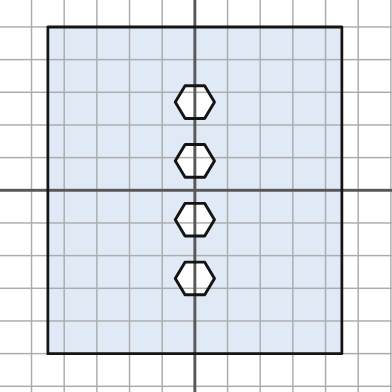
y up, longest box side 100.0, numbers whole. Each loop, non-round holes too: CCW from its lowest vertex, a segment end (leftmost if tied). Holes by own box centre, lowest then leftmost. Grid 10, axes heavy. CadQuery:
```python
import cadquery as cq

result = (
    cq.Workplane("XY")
    .moveTo(-45.0, -50.0)
    .lineTo(45.0, -50.0)
    .lineTo(45.0, 50.0)
    .lineTo(-45.0, 50.0)
    .close()
    .moveTo(-3.0, -32.0)
    .lineTo(3.0, -32.0)
    .lineTo(6.0, -27.0)
    .lineTo(3.0, -22.0)
    .lineTo(-3.0, -22.0)
    .lineTo(-6.0, -27.0)
    .close()
    .moveTo(-3.0, -14.0)
    .lineTo(3.0, -14.0)
    .lineTo(6.0, -9.0)
    .lineTo(3.0, -4.0)
    .lineTo(-3.0, -4.0)
    .lineTo(-6.0, -9.0)
    .close()
    .moveTo(-3.0, 4.0)
    .lineTo(3.0, 4.0)
    .lineTo(6.0, 9.0)
    .lineTo(3.0, 14.0)
    .lineTo(-3.0, 14.0)
    .lineTo(-6.0, 9.0)
    .close()
    .moveTo(-3.0, 22.0)
    .lineTo(3.0, 22.0)
    .lineTo(6.0, 27.0)
    .lineTo(3.0, 32.0)
    .lineTo(-3.0, 32.0)
    .lineTo(-6.0, 27.0)
    .close()
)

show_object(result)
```